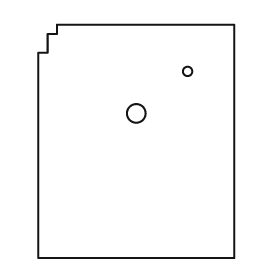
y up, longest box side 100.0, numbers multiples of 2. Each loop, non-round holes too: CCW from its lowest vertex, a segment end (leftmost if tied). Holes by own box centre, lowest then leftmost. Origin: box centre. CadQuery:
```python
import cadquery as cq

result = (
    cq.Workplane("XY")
    .moveTo(-42.0, -50.0)
    .lineTo(42.0, -50.0)
    .lineTo(42.0, 50.0)
    .lineTo(-34.0, 50.0)
    .lineTo(-34.0, 46.0)
    .lineTo(-38.0, 46.0)
    .lineTo(-38.0, 38.0)
    .lineTo(-42.0, 38.0)
    .close()
    .moveTo(0.0, 12.0)
    .circle(4.0)
    .moveTo(22.0, 30.0)
    .circle(2.0)
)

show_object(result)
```